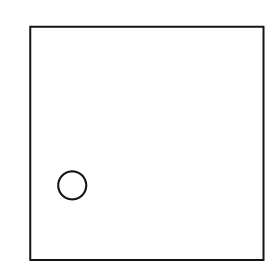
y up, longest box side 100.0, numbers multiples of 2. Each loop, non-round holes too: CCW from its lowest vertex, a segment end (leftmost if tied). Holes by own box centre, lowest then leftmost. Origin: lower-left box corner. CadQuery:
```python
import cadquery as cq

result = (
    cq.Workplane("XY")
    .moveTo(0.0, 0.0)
    .lineTo(100.0, 0.0)
    .lineTo(100.0, 100.0)
    .lineTo(0.0, 100.0)
    .close()
    .moveTo(18.0, 32.0)
    .circle(6.0)
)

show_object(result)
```